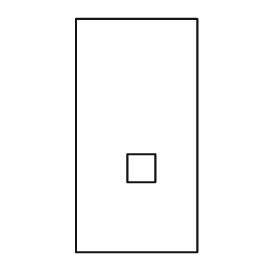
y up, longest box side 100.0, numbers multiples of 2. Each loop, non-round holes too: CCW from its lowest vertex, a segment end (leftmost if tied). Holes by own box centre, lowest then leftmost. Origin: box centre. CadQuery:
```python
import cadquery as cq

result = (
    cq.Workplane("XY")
    .moveTo(-26.0, -50.0)
    .lineTo(26.0, -50.0)
    .lineTo(26.0, 50.0)
    .lineTo(-26.0, 50.0)
    .close()
    .moveTo(-4.0, -20.0)
    .lineTo(8.0, -20.0)
    .lineTo(8.0, -8.0)
    .lineTo(-4.0, -8.0)
    .close()
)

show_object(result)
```